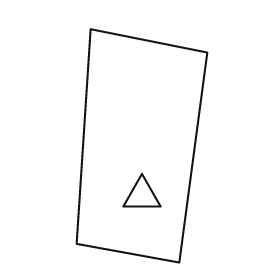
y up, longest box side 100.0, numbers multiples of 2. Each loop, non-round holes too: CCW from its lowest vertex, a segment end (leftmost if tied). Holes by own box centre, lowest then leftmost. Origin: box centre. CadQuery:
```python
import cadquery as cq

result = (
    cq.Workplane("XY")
    .moveTo(16.0, -50.0)
    .lineTo(28.0, 40.0)
    .lineTo(-22.0, 50.0)
    .lineTo(-28.0, -42.0)
    .close()
    .moveTo(-8.0, -26.0)
    .lineTo(8.0, -26.0)
    .lineTo(0.0, -12.0)
    .close()
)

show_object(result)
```